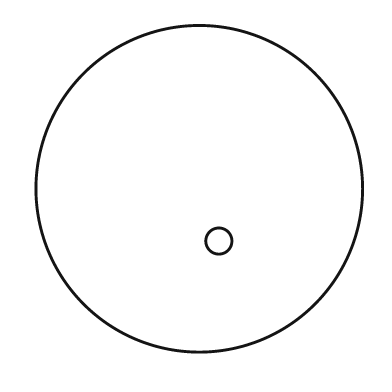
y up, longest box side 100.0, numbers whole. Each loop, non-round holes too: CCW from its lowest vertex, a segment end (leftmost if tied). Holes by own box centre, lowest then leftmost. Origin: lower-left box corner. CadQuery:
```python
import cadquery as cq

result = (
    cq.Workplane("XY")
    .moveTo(50.0, 50.0)
    .circle(50.0)
    .moveTo(56.0, 34.0)
    .circle(4.0)
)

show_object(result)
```